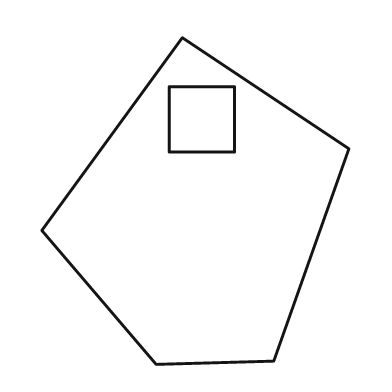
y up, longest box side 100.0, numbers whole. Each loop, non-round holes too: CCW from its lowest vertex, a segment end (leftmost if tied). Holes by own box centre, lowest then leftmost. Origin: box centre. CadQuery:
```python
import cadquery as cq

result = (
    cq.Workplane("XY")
    .moveTo(-12.0, -50.0)
    .lineTo(24.0, -49.0)
    .lineTo(47.0, 16.0)
    .lineTo(-4.0, 50.0)
    .lineTo(-47.0, -9.0)
    .close()
    .moveTo(-8.0, 15.0)
    .lineTo(12.0, 15.0)
    .lineTo(12.0, 35.0)
    .lineTo(-8.0, 35.0)
    .close()
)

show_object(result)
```